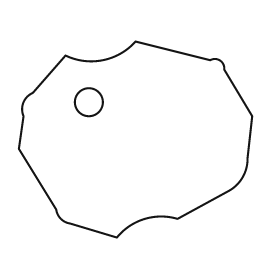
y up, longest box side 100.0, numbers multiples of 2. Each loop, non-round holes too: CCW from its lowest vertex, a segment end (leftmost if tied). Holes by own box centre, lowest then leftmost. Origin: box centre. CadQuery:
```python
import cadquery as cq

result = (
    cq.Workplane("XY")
    .moveTo(-8.0, -42.0)
    .threePointArc((4.0, -34.0), (18.0, -34.0))
    .lineTo(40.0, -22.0)
    .threePointArc((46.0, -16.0), (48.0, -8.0))
    .lineTo(50.0, 10.0)
    .lineTo(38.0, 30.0)
    .threePointArc((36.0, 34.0), (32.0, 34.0))
    .lineTo(0.0, 42.0)
    .threePointArc((-14.0, 34.0), (-30.0, 36.0))
    .lineTo(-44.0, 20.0)
    .threePointArc((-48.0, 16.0), (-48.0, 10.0))
    .lineTo(-50.0, -4.0)
    .lineTo(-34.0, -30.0)
    .threePointArc((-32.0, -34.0), (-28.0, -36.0))
    .close()
    .moveTo(-20.0, 16.0)
    .circle(6.0)
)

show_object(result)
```